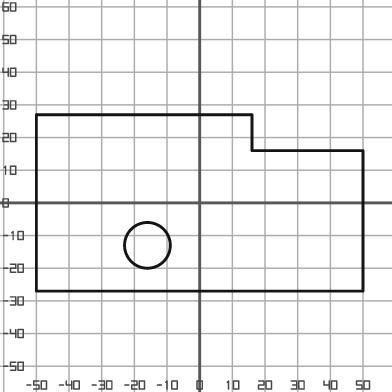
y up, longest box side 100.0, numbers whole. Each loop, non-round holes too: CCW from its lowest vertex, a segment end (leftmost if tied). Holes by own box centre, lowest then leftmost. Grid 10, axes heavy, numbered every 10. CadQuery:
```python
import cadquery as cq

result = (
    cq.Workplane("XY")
    .moveTo(-50.0, -27.0)
    .lineTo(50.0, -27.0)
    .lineTo(50.0, 16.0)
    .lineTo(16.0, 16.0)
    .lineTo(16.0, 27.0)
    .lineTo(-50.0, 27.0)
    .close()
    .moveTo(-16.0, -13.0)
    .circle(7.0)
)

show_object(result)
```